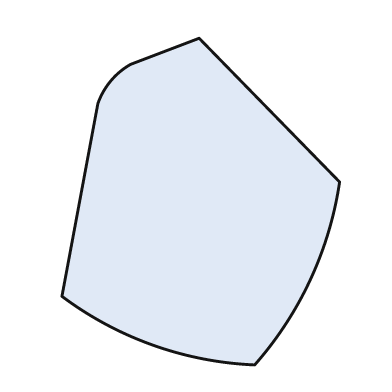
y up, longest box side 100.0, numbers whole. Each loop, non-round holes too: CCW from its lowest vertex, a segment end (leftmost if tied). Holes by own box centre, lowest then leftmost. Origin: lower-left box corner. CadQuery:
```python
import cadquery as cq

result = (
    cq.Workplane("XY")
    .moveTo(59.0, 0.0)
    .threePointArc((76.0, 26.0), (85.0, 56.0))
    .lineTo(42.0, 100.0)
    .lineTo(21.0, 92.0)
    .threePointArc((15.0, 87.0), (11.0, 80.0))
    .lineTo(0.0, 21.0)
    .threePointArc((28.0, 6.0), (59.0, 0.0))
    .close()
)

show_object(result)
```